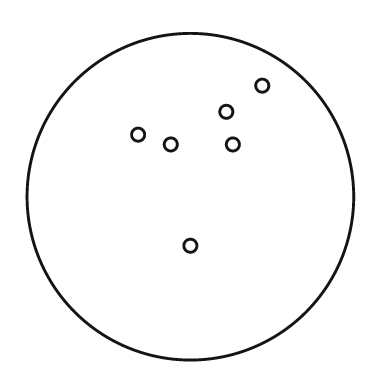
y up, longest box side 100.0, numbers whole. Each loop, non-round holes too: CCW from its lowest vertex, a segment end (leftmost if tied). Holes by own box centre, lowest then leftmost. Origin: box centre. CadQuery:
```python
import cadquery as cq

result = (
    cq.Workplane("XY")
    .moveTo(0.0, 0.0)
    .circle(50.0)
    .moveTo(0.0, -15.0)
    .circle(2.0)
    .moveTo(-6.0, 16.0)
    .circle(2.0)
    .moveTo(13.0, 16.0)
    .circle(2.0)
    .moveTo(-16.0, 19.0)
    .circle(2.0)
    .moveTo(11.0, 26.0)
    .circle(2.0)
    .moveTo(22.0, 34.0)
    .circle(2.0)
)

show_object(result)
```